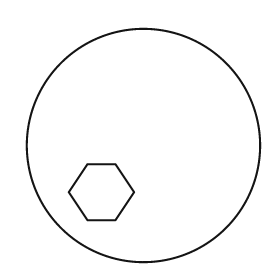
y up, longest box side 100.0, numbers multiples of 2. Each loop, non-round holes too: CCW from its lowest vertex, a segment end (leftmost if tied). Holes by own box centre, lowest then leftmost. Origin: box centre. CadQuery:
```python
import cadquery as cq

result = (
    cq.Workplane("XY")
    .moveTo(0.0, 0.0)
    .circle(50.0)
    .moveTo(-24.0, -32.0)
    .lineTo(-12.0, -32.0)
    .lineTo(-4.0, -20.0)
    .lineTo(-12.0, -8.0)
    .lineTo(-24.0, -8.0)
    .lineTo(-32.0, -20.0)
    .close()
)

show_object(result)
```